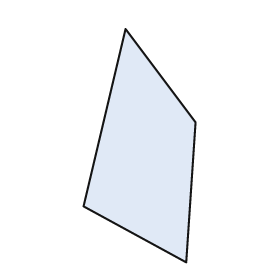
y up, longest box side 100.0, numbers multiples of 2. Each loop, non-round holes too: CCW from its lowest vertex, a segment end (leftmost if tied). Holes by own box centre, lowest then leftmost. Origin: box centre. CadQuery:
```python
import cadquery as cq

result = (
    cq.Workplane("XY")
    .moveTo(20.0, -50.0)
    .lineTo(24.0, 10.0)
    .lineTo(-6.0, 50.0)
    .lineTo(-24.0, -26.0)
    .close()
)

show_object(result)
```